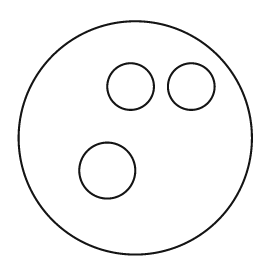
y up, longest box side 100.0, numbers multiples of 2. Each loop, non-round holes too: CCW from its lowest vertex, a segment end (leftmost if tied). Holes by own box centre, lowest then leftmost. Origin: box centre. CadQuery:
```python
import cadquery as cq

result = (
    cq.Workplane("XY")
    .moveTo(0.0, 0.0)
    .circle(50.0)
    .moveTo(-12.0, -14.0)
    .circle(12.0)
    .moveTo(-2.0, 22.0)
    .circle(10.0)
    .moveTo(24.0, 22.0)
    .circle(10.0)
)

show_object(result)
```